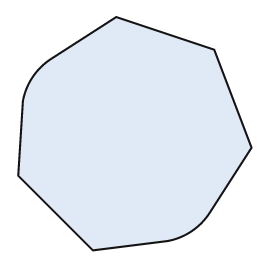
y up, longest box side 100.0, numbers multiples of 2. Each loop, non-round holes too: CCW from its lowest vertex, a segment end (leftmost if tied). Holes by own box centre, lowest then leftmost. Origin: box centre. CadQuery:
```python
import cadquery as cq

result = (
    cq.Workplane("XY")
    .moveTo(-18.0, -50.0)
    .lineTo(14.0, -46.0)
    .threePointArc((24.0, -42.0), (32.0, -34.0))
    .lineTo(50.0, -6.0)
    .lineTo(34.0, 36.0)
    .lineTo(-8.0, 50.0)
    .lineTo(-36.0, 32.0)
    .threePointArc((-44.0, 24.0), (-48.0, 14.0))
    .lineTo(-50.0, -18.0)
    .close()
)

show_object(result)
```